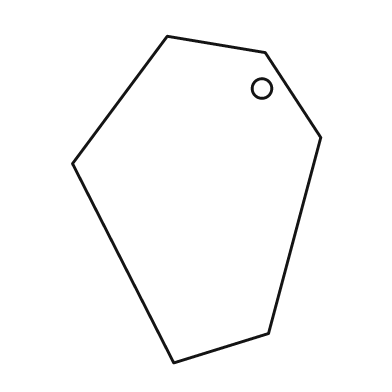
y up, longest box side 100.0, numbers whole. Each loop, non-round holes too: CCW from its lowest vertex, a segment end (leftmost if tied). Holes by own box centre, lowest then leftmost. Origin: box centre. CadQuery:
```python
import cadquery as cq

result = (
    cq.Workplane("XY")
    .moveTo(-7.0, -50.0)
    .lineTo(22.0, -41.0)
    .lineTo(38.0, 19.0)
    .lineTo(21.0, 45.0)
    .lineTo(-9.0, 50.0)
    .lineTo(-38.0, 11.0)
    .close()
    .moveTo(20.0, 34.0)
    .circle(3.0)
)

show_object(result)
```